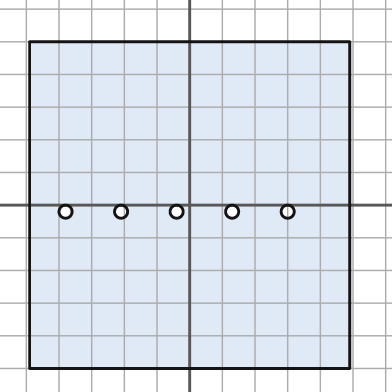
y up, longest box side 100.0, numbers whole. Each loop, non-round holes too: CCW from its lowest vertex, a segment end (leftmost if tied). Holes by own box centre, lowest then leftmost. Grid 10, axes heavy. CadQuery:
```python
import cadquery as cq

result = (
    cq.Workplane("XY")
    .moveTo(-49.0, -50.0)
    .lineTo(49.0, -50.0)
    .lineTo(49.0, 50.0)
    .lineTo(-49.0, 50.0)
    .close()
    .moveTo(-38.0, -2.0)
    .circle(2.0)
    .moveTo(-21.0, -2.0)
    .circle(2.0)
    .moveTo(-4.0, -2.0)
    .circle(2.0)
    .moveTo(13.0, -2.0)
    .circle(2.0)
    .moveTo(30.0, -2.0)
    .circle(2.0)
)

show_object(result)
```